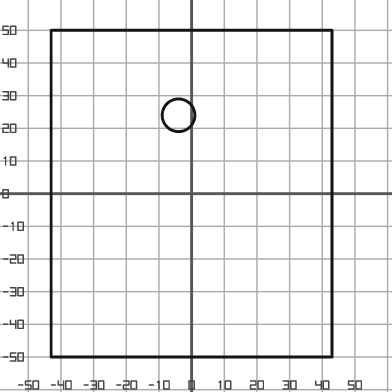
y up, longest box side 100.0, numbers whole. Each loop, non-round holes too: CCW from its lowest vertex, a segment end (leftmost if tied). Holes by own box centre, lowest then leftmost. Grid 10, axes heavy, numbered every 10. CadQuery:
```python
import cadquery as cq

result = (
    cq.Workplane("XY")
    .moveTo(-43.0, -50.0)
    .lineTo(43.0, -50.0)
    .lineTo(43.0, 50.0)
    .lineTo(-43.0, 50.0)
    .close()
    .moveTo(-4.0, 24.0)
    .circle(5.0)
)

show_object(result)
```